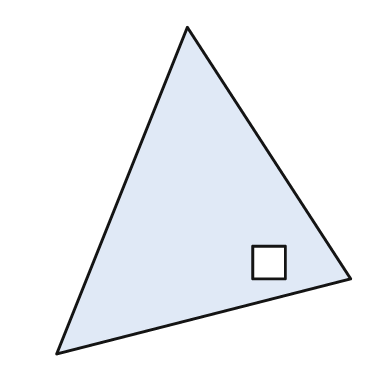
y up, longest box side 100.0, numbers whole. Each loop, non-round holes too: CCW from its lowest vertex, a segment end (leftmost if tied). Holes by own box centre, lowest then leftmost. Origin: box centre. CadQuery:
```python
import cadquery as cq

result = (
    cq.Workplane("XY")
    .moveTo(-45.0, -50.0)
    .lineTo(45.0, -27.0)
    .lineTo(-5.0, 50.0)
    .close()
    .moveTo(15.0, -27.0)
    .lineTo(25.0, -27.0)
    .lineTo(25.0, -17.0)
    .lineTo(15.0, -17.0)
    .close()
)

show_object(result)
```